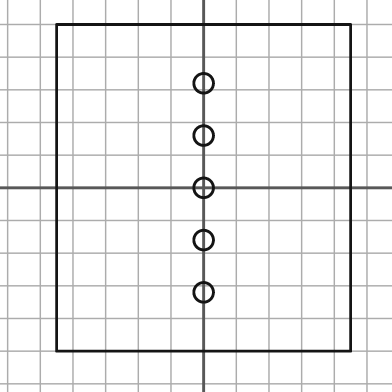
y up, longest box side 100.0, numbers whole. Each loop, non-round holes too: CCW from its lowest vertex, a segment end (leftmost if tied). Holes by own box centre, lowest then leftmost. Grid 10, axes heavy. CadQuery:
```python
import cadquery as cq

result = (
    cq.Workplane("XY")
    .moveTo(-45.0, -50.0)
    .lineTo(45.0, -50.0)
    .lineTo(45.0, 50.0)
    .lineTo(-45.0, 50.0)
    .close()
    .moveTo(0.0, -32.0)
    .circle(3.0)
    .moveTo(0.0, -16.0)
    .circle(3.0)
    .moveTo(0.0, 0.0)
    .circle(3.0)
    .moveTo(0.0, 16.0)
    .circle(3.0)
    .moveTo(0.0, 32.0)
    .circle(3.0)
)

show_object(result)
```